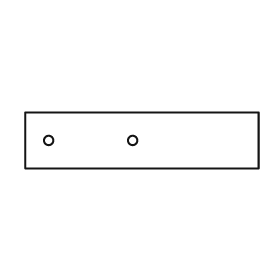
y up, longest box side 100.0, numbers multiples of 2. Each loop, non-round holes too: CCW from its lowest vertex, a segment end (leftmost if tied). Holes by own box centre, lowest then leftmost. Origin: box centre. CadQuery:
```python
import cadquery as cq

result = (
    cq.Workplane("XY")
    .moveTo(-50.0, -12.0)
    .lineTo(50.0, -12.0)
    .lineTo(50.0, 12.0)
    .lineTo(-50.0, 12.0)
    .close()
    .moveTo(-40.0, 0.0)
    .circle(2.0)
    .moveTo(-4.0, 0.0)
    .circle(2.0)
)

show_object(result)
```